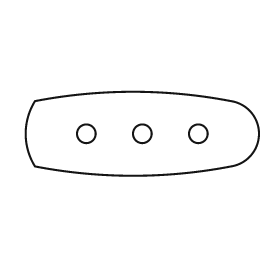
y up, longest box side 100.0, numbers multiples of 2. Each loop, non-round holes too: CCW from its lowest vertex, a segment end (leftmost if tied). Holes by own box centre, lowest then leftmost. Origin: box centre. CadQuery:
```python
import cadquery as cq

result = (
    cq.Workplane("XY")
    .moveTo(-46.0, -14.0)
    .threePointArc((-4.0, -18.0), (38.0, -14.0))
    .threePointArc((50.0, 0.0), (38.0, 14.0))
    .threePointArc((-4.0, 18.0), (-46.0, 14.0))
    .threePointArc((-50.0, 0.0), (-46.0, -14.0))
    .close()
    .moveTo(-24.0, 0.0)
    .circle(4.0)
    .moveTo(0.0, 0.0)
    .circle(4.0)
    .moveTo(24.0, 0.0)
    .circle(4.0)
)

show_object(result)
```